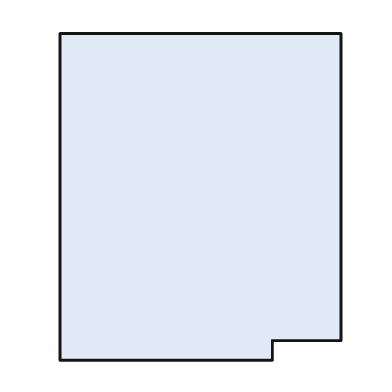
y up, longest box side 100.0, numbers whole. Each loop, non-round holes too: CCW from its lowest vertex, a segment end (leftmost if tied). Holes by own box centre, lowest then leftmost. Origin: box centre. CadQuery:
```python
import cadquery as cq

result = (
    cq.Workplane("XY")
    .moveTo(-43.0, -50.0)
    .lineTo(22.0, -50.0)
    .lineTo(22.0, -44.0)
    .lineTo(43.0, -44.0)
    .lineTo(43.0, 50.0)
    .lineTo(-43.0, 50.0)
    .close()
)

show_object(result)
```